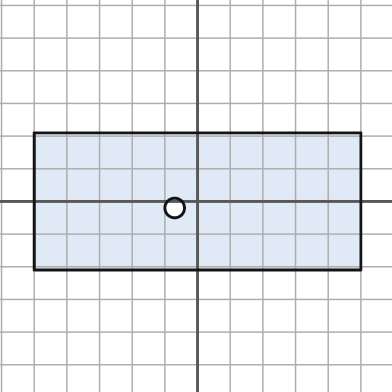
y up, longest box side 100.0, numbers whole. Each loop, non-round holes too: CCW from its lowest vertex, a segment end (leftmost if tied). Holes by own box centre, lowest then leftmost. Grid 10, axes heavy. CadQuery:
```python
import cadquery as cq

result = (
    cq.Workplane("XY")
    .moveTo(-50.0, -21.0)
    .lineTo(50.0, -21.0)
    .lineTo(50.0, 21.0)
    .lineTo(-50.0, 21.0)
    .close()
    .moveTo(-7.0, -2.0)
    .circle(3.0)
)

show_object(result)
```